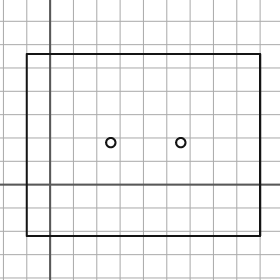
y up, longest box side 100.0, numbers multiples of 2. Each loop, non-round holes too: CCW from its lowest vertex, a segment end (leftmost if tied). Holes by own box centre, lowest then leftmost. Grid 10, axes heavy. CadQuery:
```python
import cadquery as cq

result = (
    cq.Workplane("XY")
    .moveTo(-10.0, -22.0)
    .lineTo(90.0, -22.0)
    .lineTo(90.0, 56.0)
    .lineTo(-10.0, 56.0)
    .close()
    .moveTo(26.0, 18.0)
    .circle(2.0)
    .moveTo(56.0, 18.0)
    .circle(2.0)
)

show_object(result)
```